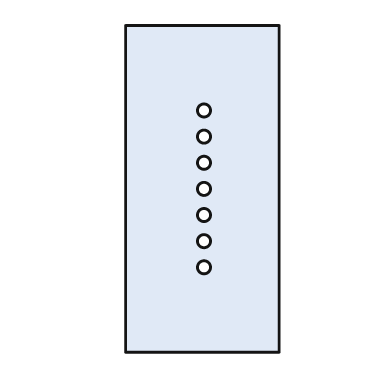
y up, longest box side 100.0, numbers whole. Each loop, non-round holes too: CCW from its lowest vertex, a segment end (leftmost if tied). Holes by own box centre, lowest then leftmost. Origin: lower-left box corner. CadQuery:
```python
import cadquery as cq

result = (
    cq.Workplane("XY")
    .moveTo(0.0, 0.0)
    .lineTo(47.0, 0.0)
    .lineTo(47.0, 100.0)
    .lineTo(0.0, 100.0)
    .close()
    .moveTo(24.0, 26.0)
    .circle(2.0)
    .moveTo(24.0, 34.0)
    .circle(2.0)
    .moveTo(24.0, 42.0)
    .circle(2.0)
    .moveTo(24.0, 50.0)
    .circle(2.0)
    .moveTo(24.0, 58.0)
    .circle(2.0)
    .moveTo(24.0, 66.0)
    .circle(2.0)
    .moveTo(24.0, 74.0)
    .circle(2.0)
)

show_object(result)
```